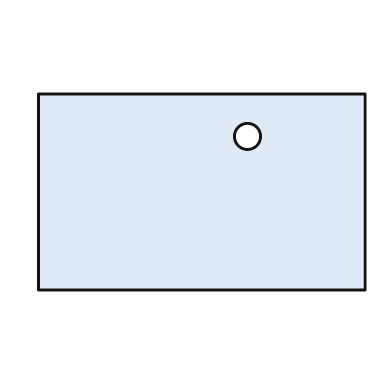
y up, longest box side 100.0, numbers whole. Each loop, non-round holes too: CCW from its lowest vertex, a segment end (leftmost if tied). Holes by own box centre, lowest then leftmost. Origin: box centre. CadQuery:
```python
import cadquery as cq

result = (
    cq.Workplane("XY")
    .moveTo(-50.0, -30.0)
    .lineTo(50.0, -30.0)
    .lineTo(50.0, 30.0)
    .lineTo(-50.0, 30.0)
    .close()
    .moveTo(14.0, 17.0)
    .circle(4.0)
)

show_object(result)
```